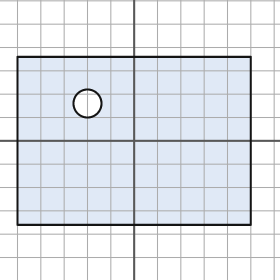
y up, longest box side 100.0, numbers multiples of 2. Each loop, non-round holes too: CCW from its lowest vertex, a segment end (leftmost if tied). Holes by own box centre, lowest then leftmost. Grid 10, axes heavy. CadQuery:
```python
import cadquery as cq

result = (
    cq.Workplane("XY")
    .moveTo(-50.0, -36.0)
    .lineTo(50.0, -36.0)
    .lineTo(50.0, 36.0)
    .lineTo(-50.0, 36.0)
    .close()
    .moveTo(-20.0, 16.0)
    .circle(6.0)
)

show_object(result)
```